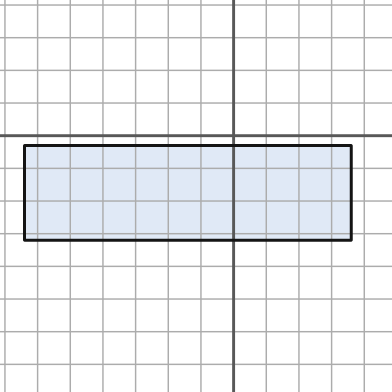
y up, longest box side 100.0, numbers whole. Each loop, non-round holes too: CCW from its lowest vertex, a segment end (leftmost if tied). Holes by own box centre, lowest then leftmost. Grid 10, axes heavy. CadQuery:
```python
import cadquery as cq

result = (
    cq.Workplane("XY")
    .moveTo(-64.0, -32.0)
    .lineTo(36.0, -32.0)
    .lineTo(36.0, -3.0)
    .lineTo(-64.0, -3.0)
    .close()
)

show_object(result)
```